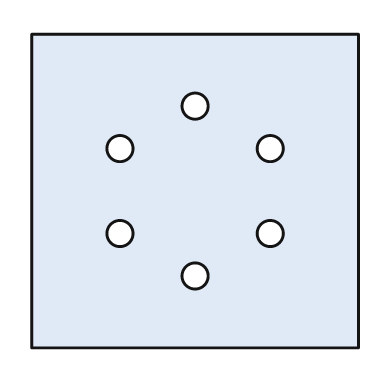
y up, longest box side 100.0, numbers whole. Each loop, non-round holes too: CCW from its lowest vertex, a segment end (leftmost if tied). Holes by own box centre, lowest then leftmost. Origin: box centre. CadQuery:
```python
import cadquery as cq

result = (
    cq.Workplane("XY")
    .moveTo(-50.0, -48.0)
    .lineTo(50.0, -48.0)
    .lineTo(50.0, 48.0)
    .lineTo(-50.0, 48.0)
    .close()
    .moveTo(0.0, -26.0)
    .circle(4.0)
    .moveTo(-23.0, -13.0)
    .circle(4.0)
    .moveTo(23.0, -13.0)
    .circle(4.0)
    .moveTo(-23.0, 13.0)
    .circle(4.0)
    .moveTo(23.0, 13.0)
    .circle(4.0)
    .moveTo(0.0, 26.0)
    .circle(4.0)
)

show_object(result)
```